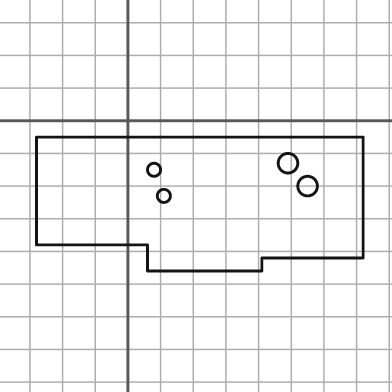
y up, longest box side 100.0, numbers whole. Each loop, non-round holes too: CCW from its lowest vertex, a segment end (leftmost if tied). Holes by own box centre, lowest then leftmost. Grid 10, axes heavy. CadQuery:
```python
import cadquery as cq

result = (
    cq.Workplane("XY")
    .moveTo(6.0, -46.0)
    .lineTo(41.0, -46.0)
    .lineTo(41.0, -42.0)
    .lineTo(72.0, -42.0)
    .lineTo(72.0, -5.0)
    .lineTo(-28.0, -5.0)
    .lineTo(-28.0, -38.0)
    .lineTo(6.0, -38.0)
    .close()
    .moveTo(11.0, -23.0)
    .circle(2.0)
    .moveTo(55.0, -20.0)
    .circle(3.0)
    .moveTo(8.0, -15.0)
    .circle(2.0)
    .moveTo(49.0, -13.0)
    .circle(3.0)
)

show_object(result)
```